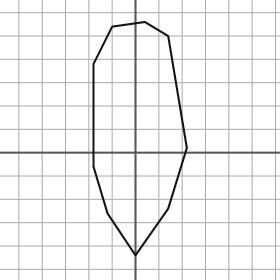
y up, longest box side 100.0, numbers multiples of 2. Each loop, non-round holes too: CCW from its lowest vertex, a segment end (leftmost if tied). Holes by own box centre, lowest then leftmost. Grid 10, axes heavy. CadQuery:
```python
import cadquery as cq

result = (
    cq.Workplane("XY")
    .moveTo(0.0, -44.0)
    .lineTo(14.0, -24.0)
    .lineTo(22.0, 2.0)
    .lineTo(14.0, 50.0)
    .lineTo(4.0, 56.0)
    .lineTo(-10.0, 54.0)
    .lineTo(-18.0, 38.0)
    .lineTo(-18.0, -6.0)
    .lineTo(-12.0, -26.0)
    .close()
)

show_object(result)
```